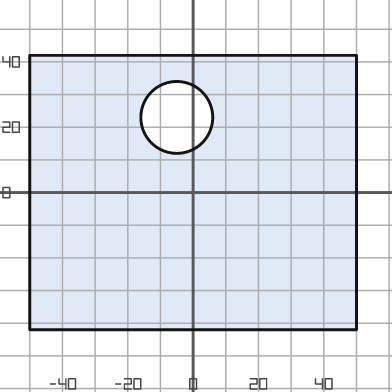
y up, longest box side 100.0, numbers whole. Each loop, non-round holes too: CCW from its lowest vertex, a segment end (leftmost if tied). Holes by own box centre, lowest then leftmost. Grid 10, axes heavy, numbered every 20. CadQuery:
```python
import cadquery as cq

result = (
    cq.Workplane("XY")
    .moveTo(-50.0, -42.0)
    .lineTo(50.0, -42.0)
    .lineTo(50.0, 42.0)
    .lineTo(-50.0, 42.0)
    .close()
    .moveTo(-5.0, 23.0)
    .circle(11.0)
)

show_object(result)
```